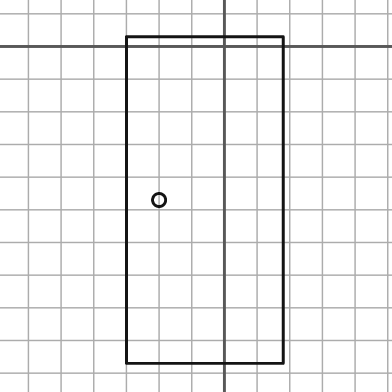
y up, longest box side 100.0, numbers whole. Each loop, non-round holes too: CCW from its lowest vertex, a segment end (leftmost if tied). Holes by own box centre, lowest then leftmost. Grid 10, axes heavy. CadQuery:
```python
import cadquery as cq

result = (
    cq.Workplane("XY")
    .moveTo(-30.0, -97.0)
    .lineTo(18.0, -97.0)
    .lineTo(18.0, 3.0)
    .lineTo(-30.0, 3.0)
    .close()
    .moveTo(-20.0, -47.0)
    .circle(2.0)
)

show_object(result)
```